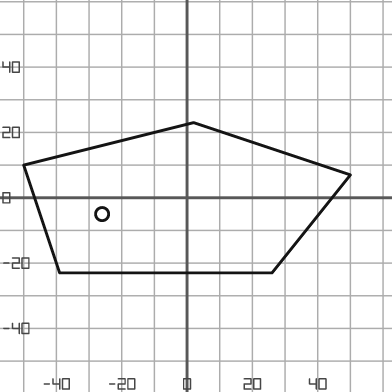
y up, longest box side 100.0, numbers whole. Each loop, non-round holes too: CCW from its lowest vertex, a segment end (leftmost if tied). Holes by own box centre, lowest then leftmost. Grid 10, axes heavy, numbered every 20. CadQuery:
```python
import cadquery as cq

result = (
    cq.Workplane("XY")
    .moveTo(-39.0, -23.0)
    .lineTo(26.0, -23.0)
    .lineTo(50.0, 7.0)
    .lineTo(2.0, 23.0)
    .lineTo(-50.0, 10.0)
    .close()
    .moveTo(-26.0, -5.0)
    .circle(2.0)
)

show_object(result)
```